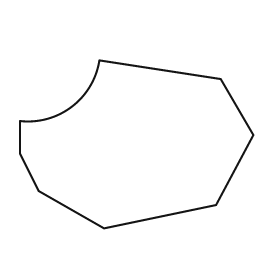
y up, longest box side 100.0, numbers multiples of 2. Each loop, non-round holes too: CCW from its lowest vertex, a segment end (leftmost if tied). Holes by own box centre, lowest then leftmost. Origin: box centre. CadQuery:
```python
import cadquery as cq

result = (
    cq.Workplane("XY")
    .moveTo(-14.0, -36.0)
    .lineTo(34.0, -26.0)
    .lineTo(50.0, 4.0)
    .lineTo(36.0, 28.0)
    .lineTo(-16.0, 36.0)
    .threePointArc((-28.0, 16.0), (-50.0, 10.0))
    .lineTo(-50.0, -4.0)
    .lineTo(-42.0, -20.0)
    .close()
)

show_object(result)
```